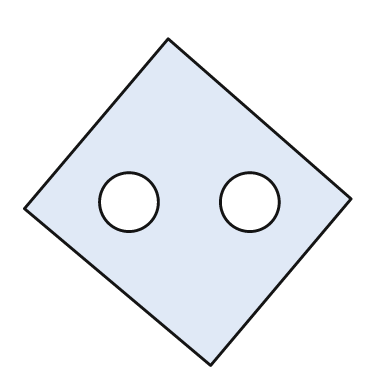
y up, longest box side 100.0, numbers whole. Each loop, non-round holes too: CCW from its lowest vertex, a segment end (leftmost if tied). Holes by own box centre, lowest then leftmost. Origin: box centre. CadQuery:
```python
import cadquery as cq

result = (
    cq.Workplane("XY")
    .moveTo(7.0, -50.0)
    .lineTo(50.0, 1.0)
    .lineTo(-6.0, 50.0)
    .lineTo(-50.0, -2.0)
    .close()
    .moveTo(-18.0, 0.0)
    .circle(9.0)
    .moveTo(19.0, 0.0)
    .circle(9.0)
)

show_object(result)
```